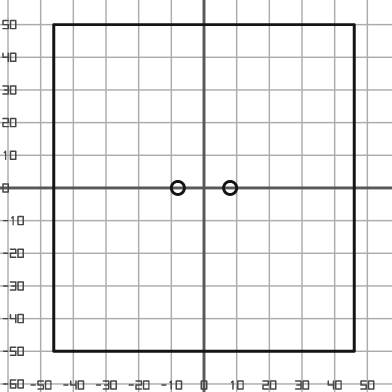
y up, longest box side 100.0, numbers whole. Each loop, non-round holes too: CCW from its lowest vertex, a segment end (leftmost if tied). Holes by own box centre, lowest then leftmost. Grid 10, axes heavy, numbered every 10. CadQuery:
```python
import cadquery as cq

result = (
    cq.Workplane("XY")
    .moveTo(-46.0, -50.0)
    .lineTo(46.0, -50.0)
    .lineTo(46.0, 50.0)
    .lineTo(-46.0, 50.0)
    .close()
    .moveTo(-8.0, 0.0)
    .circle(2.0)
    .moveTo(8.0, 0.0)
    .circle(2.0)
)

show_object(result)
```